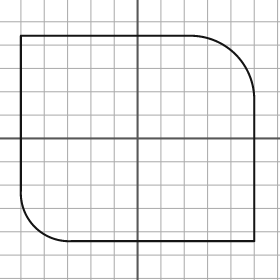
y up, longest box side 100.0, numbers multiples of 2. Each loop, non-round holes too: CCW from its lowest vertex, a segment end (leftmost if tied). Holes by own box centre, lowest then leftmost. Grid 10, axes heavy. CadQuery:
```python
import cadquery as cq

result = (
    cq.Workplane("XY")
    .moveTo(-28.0, -44.0)
    .lineTo(50.0, -44.0)
    .lineTo(50.0, 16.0)
    .threePointArc((42.0, 36.0), (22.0, 44.0))
    .lineTo(-50.0, 44.0)
    .lineTo(-50.0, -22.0)
    .threePointArc((-44.0, -38.0), (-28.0, -44.0))
    .close()
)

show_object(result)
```